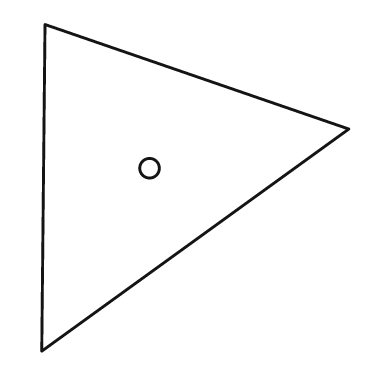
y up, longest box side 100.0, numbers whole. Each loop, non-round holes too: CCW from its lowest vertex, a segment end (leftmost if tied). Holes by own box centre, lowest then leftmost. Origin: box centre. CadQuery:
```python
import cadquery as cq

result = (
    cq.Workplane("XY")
    .moveTo(-47.0, -50.0)
    .lineTo(47.0, 18.0)
    .lineTo(-46.0, 50.0)
    .close()
    .moveTo(-14.0, 6.0)
    .circle(3.0)
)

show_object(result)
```